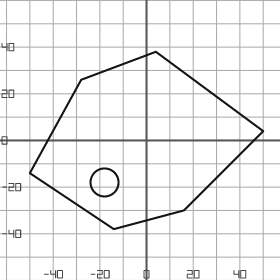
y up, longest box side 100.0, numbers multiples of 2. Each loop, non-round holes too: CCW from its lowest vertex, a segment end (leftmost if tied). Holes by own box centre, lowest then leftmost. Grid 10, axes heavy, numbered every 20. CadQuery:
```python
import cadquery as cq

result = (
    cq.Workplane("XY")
    .moveTo(-14.0, -38.0)
    .lineTo(16.0, -30.0)
    .lineTo(50.0, 4.0)
    .lineTo(4.0, 38.0)
    .lineTo(-28.0, 26.0)
    .lineTo(-50.0, -14.0)
    .close()
    .moveTo(-18.0, -18.0)
    .circle(6.0)
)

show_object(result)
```